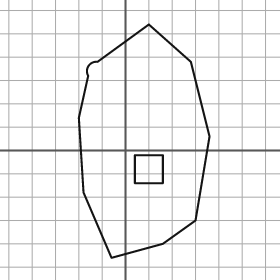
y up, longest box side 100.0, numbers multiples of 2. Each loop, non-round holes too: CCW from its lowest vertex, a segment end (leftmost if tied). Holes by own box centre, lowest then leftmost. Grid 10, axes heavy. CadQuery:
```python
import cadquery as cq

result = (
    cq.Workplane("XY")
    .moveTo(-6.0, -46.0)
    .lineTo(16.0, -40.0)
    .lineTo(30.0, -30.0)
    .lineTo(36.0, 6.0)
    .lineTo(28.0, 38.0)
    .lineTo(10.0, 54.0)
    .lineTo(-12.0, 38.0)
    .threePointArc((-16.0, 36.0), (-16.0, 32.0))
    .lineTo(-20.0, 14.0)
    .lineTo(-18.0, -18.0)
    .close()
    .moveTo(4.0, -14.0)
    .lineTo(16.0, -14.0)
    .lineTo(16.0, -2.0)
    .lineTo(4.0, -2.0)
    .close()
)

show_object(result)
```